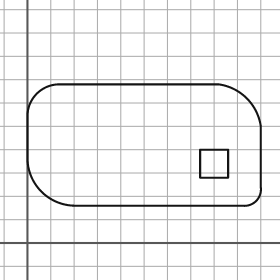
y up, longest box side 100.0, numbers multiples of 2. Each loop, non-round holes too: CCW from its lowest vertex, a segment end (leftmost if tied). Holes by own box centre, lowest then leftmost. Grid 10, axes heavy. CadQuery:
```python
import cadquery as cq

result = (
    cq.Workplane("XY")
    .moveTo(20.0, 16.0)
    .lineTo(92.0, 16.0)
    .threePointArc((98.0, 18.0), (100.0, 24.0))
    .lineTo(100.0, 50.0)
    .threePointArc((94.0, 62.0), (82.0, 68.0))
    .lineTo(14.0, 68.0)
    .threePointArc((4.0, 64.0), (0.0, 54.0))
    .lineTo(0.0, 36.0)
    .threePointArc((6.0, 22.0), (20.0, 16.0))
    .close()
    .moveTo(74.0, 28.0)
    .lineTo(86.0, 28.0)
    .lineTo(86.0, 40.0)
    .lineTo(74.0, 40.0)
    .close()
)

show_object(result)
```